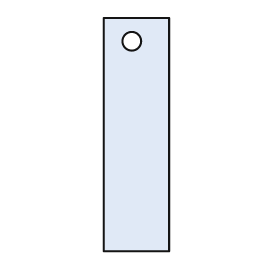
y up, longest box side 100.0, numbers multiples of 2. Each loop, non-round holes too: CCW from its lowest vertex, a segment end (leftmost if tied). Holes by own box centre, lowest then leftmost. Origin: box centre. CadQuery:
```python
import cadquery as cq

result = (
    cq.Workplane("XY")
    .moveTo(-14.0, -50.0)
    .lineTo(14.0, -50.0)
    .lineTo(14.0, 50.0)
    .lineTo(-14.0, 50.0)
    .close()
    .moveTo(-2.0, 40.0)
    .circle(4.0)
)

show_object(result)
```